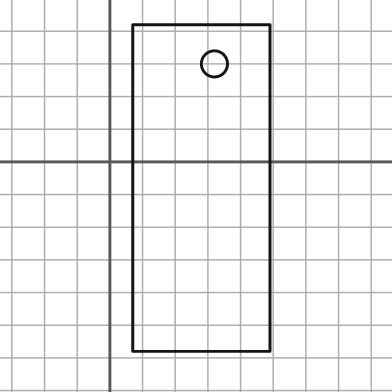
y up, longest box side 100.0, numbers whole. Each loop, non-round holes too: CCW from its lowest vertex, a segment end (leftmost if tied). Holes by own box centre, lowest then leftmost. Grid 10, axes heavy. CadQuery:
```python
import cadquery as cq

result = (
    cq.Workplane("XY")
    .moveTo(7.0, -58.0)
    .lineTo(49.0, -58.0)
    .lineTo(49.0, 42.0)
    .lineTo(7.0, 42.0)
    .close()
    .moveTo(32.0, 30.0)
    .circle(4.0)
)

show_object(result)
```